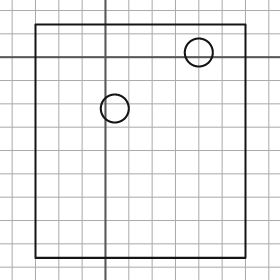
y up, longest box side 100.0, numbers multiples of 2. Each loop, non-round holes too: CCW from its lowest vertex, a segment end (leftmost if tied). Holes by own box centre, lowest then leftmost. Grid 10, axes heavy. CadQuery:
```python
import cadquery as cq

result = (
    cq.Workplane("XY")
    .moveTo(-30.0, -86.0)
    .lineTo(60.0, -86.0)
    .lineTo(60.0, 14.0)
    .lineTo(-30.0, 14.0)
    .close()
    .moveTo(4.0, -22.0)
    .circle(6.0)
    .moveTo(40.0, 2.0)
    .circle(6.0)
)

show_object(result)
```